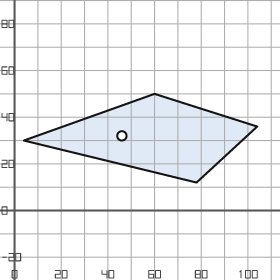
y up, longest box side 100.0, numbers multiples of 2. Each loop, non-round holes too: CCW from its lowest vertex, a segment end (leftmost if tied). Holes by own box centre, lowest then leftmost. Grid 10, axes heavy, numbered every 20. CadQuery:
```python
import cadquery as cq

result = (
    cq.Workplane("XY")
    .moveTo(78.0, 12.0)
    .lineTo(104.0, 36.0)
    .lineTo(60.0, 50.0)
    .lineTo(4.0, 30.0)
    .close()
    .moveTo(46.0, 32.0)
    .circle(2.0)
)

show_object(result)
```